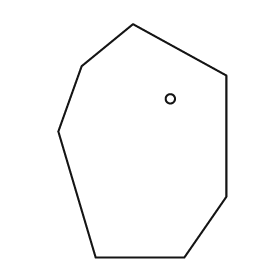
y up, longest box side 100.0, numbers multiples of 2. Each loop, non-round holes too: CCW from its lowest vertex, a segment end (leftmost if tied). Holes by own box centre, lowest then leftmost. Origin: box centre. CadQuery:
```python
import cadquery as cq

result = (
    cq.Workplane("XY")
    .moveTo(-20.0, -50.0)
    .lineTo(18.0, -50.0)
    .lineTo(36.0, -24.0)
    .lineTo(36.0, 28.0)
    .lineTo(-4.0, 50.0)
    .lineTo(-26.0, 32.0)
    .lineTo(-36.0, 4.0)
    .close()
    .moveTo(12.0, 18.0)
    .circle(2.0)
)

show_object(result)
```